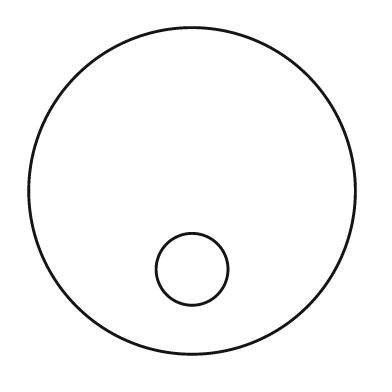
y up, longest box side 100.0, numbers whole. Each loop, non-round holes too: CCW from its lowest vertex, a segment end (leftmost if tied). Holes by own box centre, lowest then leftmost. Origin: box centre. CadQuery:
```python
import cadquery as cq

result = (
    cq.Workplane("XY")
    .moveTo(0.0, 0.0)
    .circle(50.0)
    .moveTo(0.0, -24.0)
    .circle(11.0)
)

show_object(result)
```